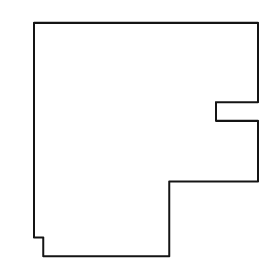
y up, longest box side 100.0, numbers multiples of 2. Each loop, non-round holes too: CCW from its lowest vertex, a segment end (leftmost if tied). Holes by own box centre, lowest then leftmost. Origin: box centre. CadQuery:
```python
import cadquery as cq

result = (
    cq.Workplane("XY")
    .moveTo(-44.0, -50.0)
    .lineTo(10.0, -50.0)
    .lineTo(10.0, -18.0)
    .lineTo(48.0, -18.0)
    .lineTo(48.0, 8.0)
    .lineTo(30.0, 8.0)
    .lineTo(30.0, 16.0)
    .lineTo(48.0, 16.0)
    .lineTo(48.0, 50.0)
    .lineTo(-48.0, 50.0)
    .lineTo(-48.0, -42.0)
    .lineTo(-44.0, -42.0)
    .close()
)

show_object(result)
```